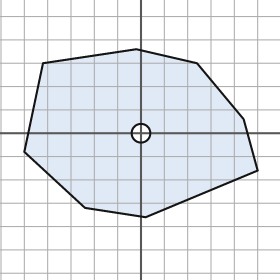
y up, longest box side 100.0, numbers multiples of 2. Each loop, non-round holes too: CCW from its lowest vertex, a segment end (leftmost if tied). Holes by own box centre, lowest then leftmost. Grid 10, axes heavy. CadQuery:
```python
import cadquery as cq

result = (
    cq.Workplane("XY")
    .moveTo(2.0, -36.0)
    .lineTo(50.0, -16.0)
    .lineTo(44.0, 6.0)
    .lineTo(24.0, 30.0)
    .lineTo(-2.0, 36.0)
    .lineTo(-42.0, 30.0)
    .lineTo(-50.0, -8.0)
    .lineTo(-24.0, -32.0)
    .close()
    .moveTo(0.0, 0.0)
    .circle(4.0)
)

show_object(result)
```